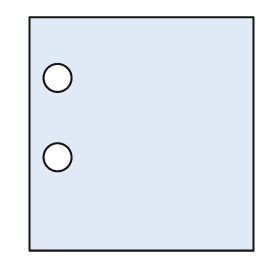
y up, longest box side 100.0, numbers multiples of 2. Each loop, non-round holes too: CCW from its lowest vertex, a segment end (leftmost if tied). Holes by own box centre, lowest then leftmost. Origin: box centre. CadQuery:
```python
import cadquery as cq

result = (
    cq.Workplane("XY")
    .moveTo(-48.0, -50.0)
    .lineTo(48.0, -50.0)
    .lineTo(48.0, 50.0)
    .lineTo(-48.0, 50.0)
    .close()
    .moveTo(-36.0, -10.0)
    .circle(6.0)
    .moveTo(-36.0, 24.0)
    .circle(6.0)
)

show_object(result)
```